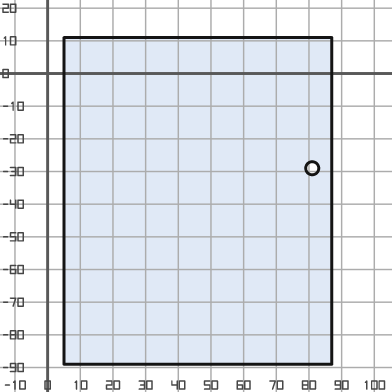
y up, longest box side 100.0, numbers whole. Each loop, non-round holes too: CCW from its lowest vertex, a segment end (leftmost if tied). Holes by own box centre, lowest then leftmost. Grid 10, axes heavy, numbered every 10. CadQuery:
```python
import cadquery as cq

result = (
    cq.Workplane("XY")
    .moveTo(5.0, -89.0)
    .lineTo(87.0, -89.0)
    .lineTo(87.0, 11.0)
    .lineTo(5.0, 11.0)
    .close()
    .moveTo(81.0, -29.0)
    .circle(2.0)
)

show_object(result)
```